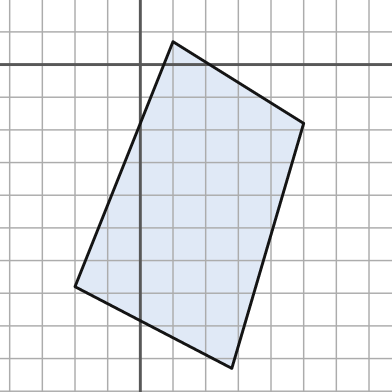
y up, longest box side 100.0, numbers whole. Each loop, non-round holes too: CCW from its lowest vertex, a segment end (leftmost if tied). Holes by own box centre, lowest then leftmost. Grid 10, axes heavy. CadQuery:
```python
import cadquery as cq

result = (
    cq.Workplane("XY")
    .moveTo(28.0, -93.0)
    .lineTo(50.0, -18.0)
    .lineTo(10.0, 7.0)
    .lineTo(-20.0, -68.0)
    .close()
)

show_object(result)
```